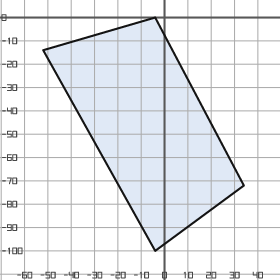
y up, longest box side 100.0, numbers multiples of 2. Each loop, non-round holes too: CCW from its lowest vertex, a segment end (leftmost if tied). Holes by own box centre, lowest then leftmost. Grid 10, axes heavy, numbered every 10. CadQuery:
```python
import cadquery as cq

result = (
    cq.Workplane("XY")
    .moveTo(-4.0, -100.0)
    .lineTo(34.0, -72.0)
    .lineTo(-4.0, 0.0)
    .lineTo(-52.0, -14.0)
    .close()
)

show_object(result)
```